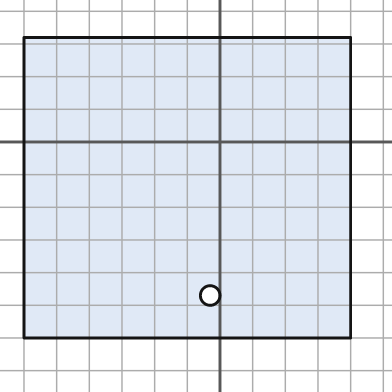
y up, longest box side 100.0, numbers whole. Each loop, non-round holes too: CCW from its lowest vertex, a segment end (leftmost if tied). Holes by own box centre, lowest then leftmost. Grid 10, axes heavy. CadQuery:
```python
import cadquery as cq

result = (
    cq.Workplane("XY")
    .moveTo(-60.0, -60.0)
    .lineTo(40.0, -60.0)
    .lineTo(40.0, 32.0)
    .lineTo(-60.0, 32.0)
    .close()
    .moveTo(-3.0, -47.0)
    .circle(3.0)
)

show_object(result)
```